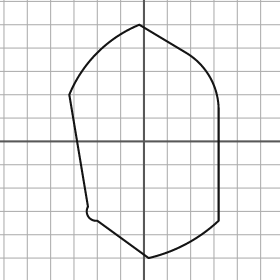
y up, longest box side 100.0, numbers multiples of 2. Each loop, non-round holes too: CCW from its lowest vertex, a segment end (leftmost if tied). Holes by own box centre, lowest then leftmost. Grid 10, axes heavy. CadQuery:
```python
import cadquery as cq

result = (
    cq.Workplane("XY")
    .moveTo(2.0, -50.0)
    .threePointArc((18.0, -44.0), (32.0, -34.0))
    .lineTo(32.0, 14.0)
    .threePointArc((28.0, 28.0), (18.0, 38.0))
    .lineTo(-2.0, 50.0)
    .threePointArc((-20.0, 38.0), (-32.0, 20.0))
    .lineTo(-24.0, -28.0)
    .threePointArc((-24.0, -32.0), (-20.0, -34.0))
    .close()
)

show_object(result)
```